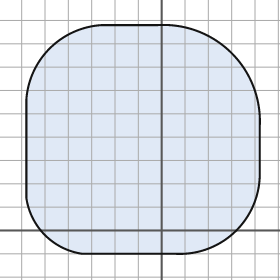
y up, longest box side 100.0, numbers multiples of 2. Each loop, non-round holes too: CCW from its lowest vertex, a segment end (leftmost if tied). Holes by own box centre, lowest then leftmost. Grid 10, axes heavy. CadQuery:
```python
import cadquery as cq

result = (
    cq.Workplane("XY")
    .moveTo(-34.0, -10.0)
    .lineTo(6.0, -10.0)
    .threePointArc((32.0, 0.0), (42.0, 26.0))
    .lineTo(42.0, 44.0)
    .threePointArc((30.0, 76.0), (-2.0, 88.0))
    .lineTo(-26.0, 88.0)
    .threePointArc((-48.0, 78.0), (-58.0, 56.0))
    .lineTo(-58.0, 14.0)
    .threePointArc((-50.0, -2.0), (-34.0, -10.0))
    .close()
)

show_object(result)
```